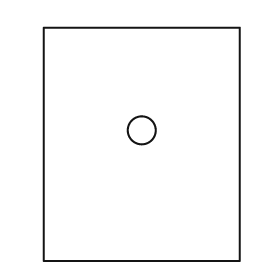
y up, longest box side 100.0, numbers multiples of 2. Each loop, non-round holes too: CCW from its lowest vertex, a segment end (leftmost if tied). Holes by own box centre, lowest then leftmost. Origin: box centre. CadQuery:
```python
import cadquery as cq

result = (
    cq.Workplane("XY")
    .moveTo(-42.0, -50.0)
    .lineTo(42.0, -50.0)
    .lineTo(42.0, 50.0)
    .lineTo(-42.0, 50.0)
    .close()
    .moveTo(0.0, 6.0)
    .circle(6.0)
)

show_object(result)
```